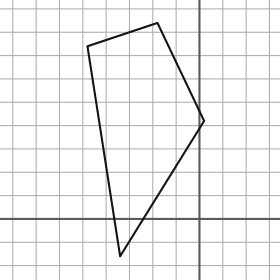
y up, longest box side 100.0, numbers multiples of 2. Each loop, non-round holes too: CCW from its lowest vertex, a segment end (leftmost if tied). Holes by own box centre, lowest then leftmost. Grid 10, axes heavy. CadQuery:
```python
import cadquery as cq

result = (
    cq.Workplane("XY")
    .moveTo(-34.0, -16.0)
    .lineTo(2.0, 42.0)
    .lineTo(-18.0, 84.0)
    .lineTo(-48.0, 74.0)
    .close()
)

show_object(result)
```